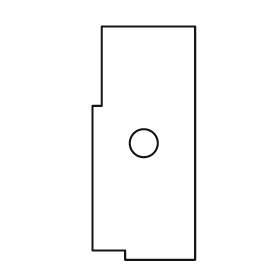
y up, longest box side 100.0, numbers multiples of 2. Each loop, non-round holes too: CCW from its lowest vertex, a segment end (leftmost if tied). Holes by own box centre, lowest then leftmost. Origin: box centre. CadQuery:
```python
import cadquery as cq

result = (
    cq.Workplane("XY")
    .moveTo(-8.0, -50.0)
    .lineTo(22.0, -50.0)
    .lineTo(22.0, 50.0)
    .lineTo(-18.0, 50.0)
    .lineTo(-18.0, 16.0)
    .lineTo(-22.0, 16.0)
    .lineTo(-22.0, -46.0)
    .lineTo(-8.0, -46.0)
    .close()
    .moveTo(0.0, 0.0)
    .circle(6.0)
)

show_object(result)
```